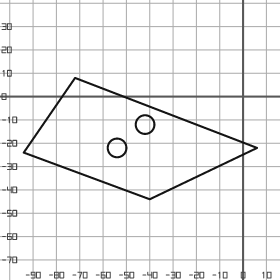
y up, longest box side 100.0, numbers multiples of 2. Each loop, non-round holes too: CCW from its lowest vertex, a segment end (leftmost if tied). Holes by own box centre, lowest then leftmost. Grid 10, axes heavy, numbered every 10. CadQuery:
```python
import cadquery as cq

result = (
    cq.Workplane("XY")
    .moveTo(-40.0, -44.0)
    .lineTo(6.0, -22.0)
    .lineTo(-72.0, 8.0)
    .lineTo(-94.0, -24.0)
    .close()
    .moveTo(-54.0, -22.0)
    .circle(4.0)
    .moveTo(-42.0, -12.0)
    .circle(4.0)
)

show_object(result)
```